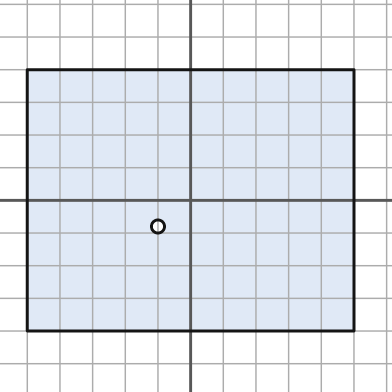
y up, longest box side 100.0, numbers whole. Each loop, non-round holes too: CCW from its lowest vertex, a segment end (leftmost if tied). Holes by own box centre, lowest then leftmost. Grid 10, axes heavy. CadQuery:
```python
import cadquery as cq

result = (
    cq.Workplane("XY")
    .moveTo(-50.0, -40.0)
    .lineTo(50.0, -40.0)
    .lineTo(50.0, 40.0)
    .lineTo(-50.0, 40.0)
    .close()
    .moveTo(-10.0, -8.0)
    .circle(2.0)
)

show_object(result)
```